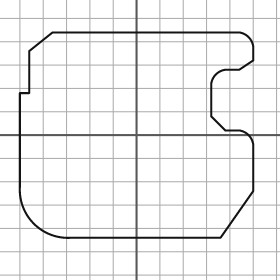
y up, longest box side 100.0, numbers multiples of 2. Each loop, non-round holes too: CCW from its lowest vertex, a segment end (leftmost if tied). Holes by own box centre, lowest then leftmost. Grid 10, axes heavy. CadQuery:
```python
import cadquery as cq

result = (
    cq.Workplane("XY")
    .moveTo(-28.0, -44.0)
    .lineTo(36.0, -44.0)
    .lineTo(50.0, -24.0)
    .lineTo(50.0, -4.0)
    .threePointArc((48.0, 0.0), (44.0, 2.0))
    .lineTo(38.0, 2.0)
    .lineTo(32.0, 8.0)
    .lineTo(32.0, 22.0)
    .threePointArc((34.0, 26.0), (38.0, 28.0))
    .lineTo(44.0, 28.0)
    .lineTo(50.0, 32.0)
    .lineTo(50.0, 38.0)
    .threePointArc((48.0, 42.0), (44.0, 44.0))
    .lineTo(-36.0, 44.0)
    .lineTo(-46.0, 36.0)
    .lineTo(-46.0, 18.0)
    .lineTo(-50.0, 18.0)
    .lineTo(-50.0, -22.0)
    .threePointArc((-44.0, -38.0), (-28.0, -44.0))
    .close()
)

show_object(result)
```